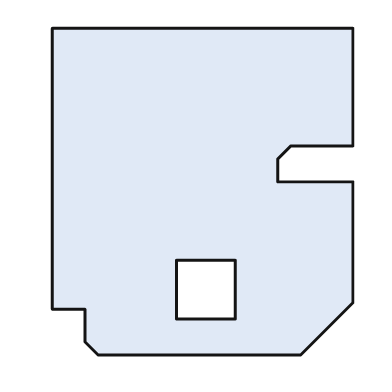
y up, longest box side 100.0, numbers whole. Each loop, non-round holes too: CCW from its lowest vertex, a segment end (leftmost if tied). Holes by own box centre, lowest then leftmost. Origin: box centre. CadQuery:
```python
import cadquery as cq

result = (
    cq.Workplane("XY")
    .moveTo(-32.0, -50.0)
    .lineTo(30.0, -50.0)
    .lineTo(46.0, -34.0)
    .lineTo(46.0, 3.0)
    .lineTo(23.0, 3.0)
    .lineTo(23.0, 10.0)
    .lineTo(27.0, 14.0)
    .lineTo(46.0, 14.0)
    .lineTo(46.0, 50.0)
    .lineTo(-46.0, 50.0)
    .lineTo(-46.0, -36.0)
    .lineTo(-36.0, -36.0)
    .lineTo(-36.0, -46.0)
    .close()
    .moveTo(-8.0, -39.0)
    .lineTo(10.0, -39.0)
    .lineTo(10.0, -21.0)
    .lineTo(-8.0, -21.0)
    .close()
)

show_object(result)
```